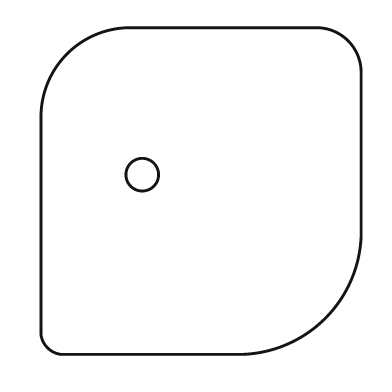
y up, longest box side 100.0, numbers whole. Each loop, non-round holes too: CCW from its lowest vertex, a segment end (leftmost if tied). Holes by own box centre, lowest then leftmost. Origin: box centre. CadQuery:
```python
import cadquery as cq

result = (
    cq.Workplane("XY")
    .moveTo(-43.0, -50.0)
    .lineTo(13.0, -50.0)
    .threePointArc((38.0, -39.0), (49.0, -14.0))
    .lineTo(49.0, 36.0)
    .threePointArc((45.0, 46.0), (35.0, 50.0))
    .lineTo(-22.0, 50.0)
    .threePointArc((-41.0, 42.0), (-49.0, 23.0))
    .lineTo(-49.0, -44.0)
    .threePointArc((-47.0, -48.0), (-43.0, -50.0))
    .close()
    .moveTo(-18.0, 5.0)
    .circle(5.0)
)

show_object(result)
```